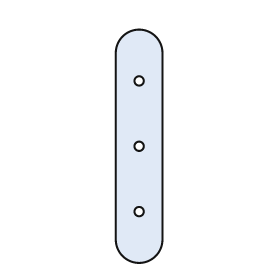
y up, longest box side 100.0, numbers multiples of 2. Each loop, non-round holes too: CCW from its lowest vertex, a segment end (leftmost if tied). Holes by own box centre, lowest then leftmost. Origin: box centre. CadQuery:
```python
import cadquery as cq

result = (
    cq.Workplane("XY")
    .moveTo(-10.0, -40.0)
    .threePointArc((0.0, -50.0), (10.0, -40.0))
    .lineTo(10.0, 40.0)
    .threePointArc((0.0, 50.0), (-10.0, 40.0))
    .close()
    .moveTo(0.0, -28.0)
    .circle(2.0)
    .moveTo(0.0, 0.0)
    .circle(2.0)
    .moveTo(0.0, 28.0)
    .circle(2.0)
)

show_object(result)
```